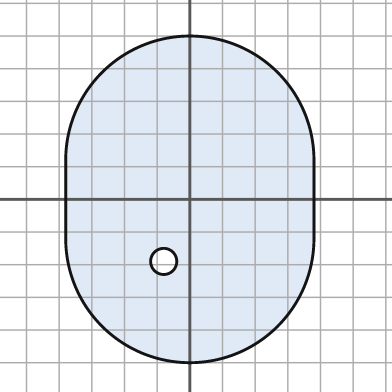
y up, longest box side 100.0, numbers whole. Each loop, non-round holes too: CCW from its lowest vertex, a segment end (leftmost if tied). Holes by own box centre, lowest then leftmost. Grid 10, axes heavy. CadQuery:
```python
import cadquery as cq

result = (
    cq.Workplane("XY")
    .moveTo(-38.0, -12.0)
    .threePointArc((0.0, -50.0), (38.0, -12.0))
    .lineTo(38.0, 12.0)
    .threePointArc((0.0, 50.0), (-38.0, 12.0))
    .close()
    .moveTo(-8.0, -19.0)
    .circle(4.0)
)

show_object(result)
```